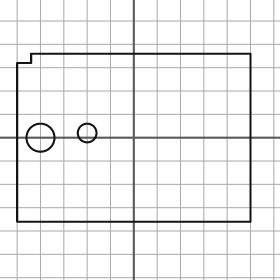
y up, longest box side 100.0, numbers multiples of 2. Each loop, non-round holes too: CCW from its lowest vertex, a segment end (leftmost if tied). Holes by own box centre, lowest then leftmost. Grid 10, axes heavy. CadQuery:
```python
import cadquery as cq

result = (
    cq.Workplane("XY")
    .moveTo(-50.0, -36.0)
    .lineTo(50.0, -36.0)
    .lineTo(50.0, 36.0)
    .lineTo(-44.0, 36.0)
    .lineTo(-44.0, 32.0)
    .lineTo(-50.0, 32.0)
    .close()
    .moveTo(-40.0, 0.0)
    .circle(6.0)
    .moveTo(-20.0, 2.0)
    .circle(4.0)
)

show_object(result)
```